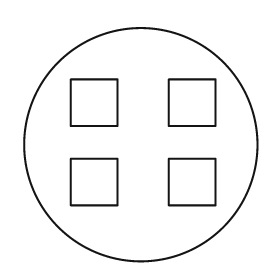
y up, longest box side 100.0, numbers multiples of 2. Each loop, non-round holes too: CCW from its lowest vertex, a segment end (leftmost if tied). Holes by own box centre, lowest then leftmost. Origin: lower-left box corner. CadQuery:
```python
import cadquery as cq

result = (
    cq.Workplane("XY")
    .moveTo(50.0, 50.0)
    .circle(50.0)
    .moveTo(20.0, 24.0)
    .lineTo(40.0, 24.0)
    .lineTo(40.0, 44.0)
    .lineTo(20.0, 44.0)
    .close()
    .moveTo(62.0, 24.0)
    .lineTo(82.0, 24.0)
    .lineTo(82.0, 44.0)
    .lineTo(62.0, 44.0)
    .close()
    .moveTo(20.0, 58.0)
    .lineTo(40.0, 58.0)
    .lineTo(40.0, 78.0)
    .lineTo(20.0, 78.0)
    .close()
    .moveTo(62.0, 58.0)
    .lineTo(82.0, 58.0)
    .lineTo(82.0, 78.0)
    .lineTo(62.0, 78.0)
    .close()
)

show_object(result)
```